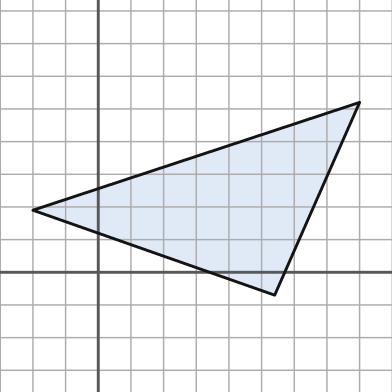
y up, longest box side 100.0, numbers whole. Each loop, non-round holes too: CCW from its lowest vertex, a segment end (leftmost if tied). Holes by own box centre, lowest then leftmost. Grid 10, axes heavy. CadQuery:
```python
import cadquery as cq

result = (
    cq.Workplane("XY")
    .moveTo(54.0, -7.0)
    .lineTo(80.0, 52.0)
    .lineTo(-20.0, 19.0)
    .close()
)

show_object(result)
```